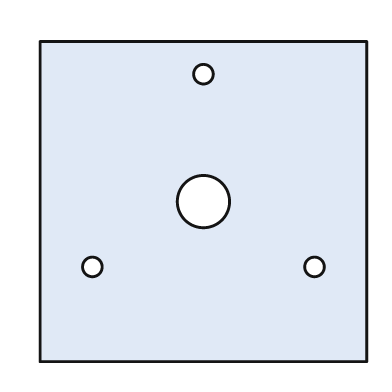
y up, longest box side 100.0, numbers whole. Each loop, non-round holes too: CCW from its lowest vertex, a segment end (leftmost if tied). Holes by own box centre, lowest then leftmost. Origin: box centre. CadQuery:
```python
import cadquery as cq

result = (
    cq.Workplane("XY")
    .moveTo(-50.0, -49.0)
    .lineTo(50.0, -49.0)
    .lineTo(50.0, 49.0)
    .lineTo(-50.0, 49.0)
    .close()
    .moveTo(-34.0, -20.0)
    .circle(3.0)
    .moveTo(34.0, -20.0)
    .circle(3.0)
    .moveTo(0.0, 0.0)
    .circle(8.0)
    .moveTo(0.0, 39.0)
    .circle(3.0)
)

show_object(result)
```